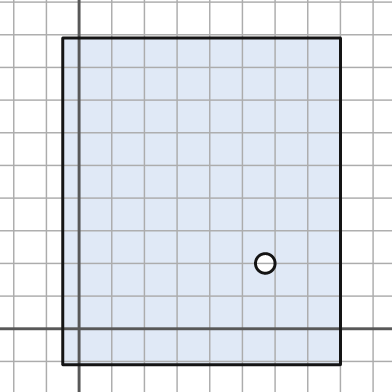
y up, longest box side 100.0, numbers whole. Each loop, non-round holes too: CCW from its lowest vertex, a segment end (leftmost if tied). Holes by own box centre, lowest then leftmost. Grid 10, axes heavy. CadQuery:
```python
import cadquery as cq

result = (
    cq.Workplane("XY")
    .moveTo(-5.0, -11.0)
    .lineTo(80.0, -11.0)
    .lineTo(80.0, 89.0)
    .lineTo(-5.0, 89.0)
    .close()
    .moveTo(57.0, 20.0)
    .circle(3.0)
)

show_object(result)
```